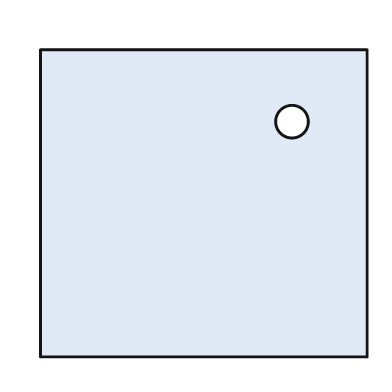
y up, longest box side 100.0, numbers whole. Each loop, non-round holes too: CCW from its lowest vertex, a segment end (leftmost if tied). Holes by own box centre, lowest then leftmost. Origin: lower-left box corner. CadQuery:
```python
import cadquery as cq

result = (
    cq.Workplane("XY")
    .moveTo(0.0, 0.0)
    .lineTo(100.0, 0.0)
    .lineTo(100.0, 94.0)
    .lineTo(0.0, 94.0)
    .close()
    .moveTo(77.0, 72.0)
    .circle(5.0)
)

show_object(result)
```